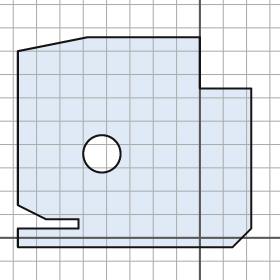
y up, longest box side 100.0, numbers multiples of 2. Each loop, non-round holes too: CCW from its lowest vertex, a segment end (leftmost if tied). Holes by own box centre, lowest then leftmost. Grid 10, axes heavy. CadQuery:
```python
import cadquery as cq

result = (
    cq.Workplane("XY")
    .moveTo(-78.0, -4.0)
    .lineTo(14.0, -4.0)
    .lineTo(22.0, 4.0)
    .lineTo(22.0, 64.0)
    .lineTo(0.0, 64.0)
    .lineTo(0.0, 86.0)
    .lineTo(-48.0, 86.0)
    .lineTo(-78.0, 80.0)
    .lineTo(-78.0, 14.0)
    .lineTo(-66.0, 8.0)
    .lineTo(-52.0, 8.0)
    .lineTo(-52.0, 4.0)
    .lineTo(-78.0, 4.0)
    .close()
    .moveTo(-42.0, 36.0)
    .circle(8.0)
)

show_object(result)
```